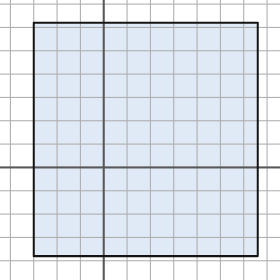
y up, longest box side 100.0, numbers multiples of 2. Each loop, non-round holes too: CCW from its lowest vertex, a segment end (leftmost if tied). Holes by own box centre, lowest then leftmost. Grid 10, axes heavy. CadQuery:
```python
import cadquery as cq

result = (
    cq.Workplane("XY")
    .moveTo(-30.0, -38.0)
    .lineTo(66.0, -38.0)
    .lineTo(66.0, 62.0)
    .lineTo(-30.0, 62.0)
    .close()
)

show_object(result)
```